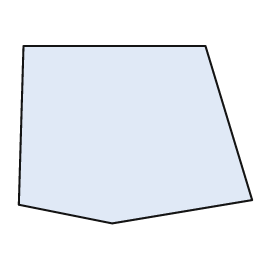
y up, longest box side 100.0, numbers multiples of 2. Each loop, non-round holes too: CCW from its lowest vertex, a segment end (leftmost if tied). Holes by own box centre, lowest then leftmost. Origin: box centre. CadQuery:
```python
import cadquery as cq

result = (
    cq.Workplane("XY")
    .moveTo(-10.0, -38.0)
    .lineTo(50.0, -28.0)
    .lineTo(30.0, 38.0)
    .lineTo(-48.0, 38.0)
    .lineTo(-50.0, -30.0)
    .close()
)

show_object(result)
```